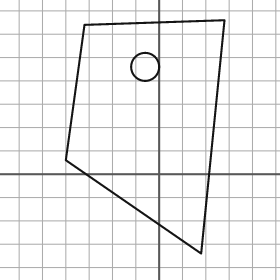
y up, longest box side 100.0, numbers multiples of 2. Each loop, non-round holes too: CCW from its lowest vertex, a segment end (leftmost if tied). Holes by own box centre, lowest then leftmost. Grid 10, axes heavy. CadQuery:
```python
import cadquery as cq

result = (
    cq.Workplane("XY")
    .moveTo(18.0, -34.0)
    .lineTo(28.0, 66.0)
    .lineTo(-32.0, 64.0)
    .lineTo(-40.0, 6.0)
    .close()
    .moveTo(-6.0, 46.0)
    .circle(6.0)
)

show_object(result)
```